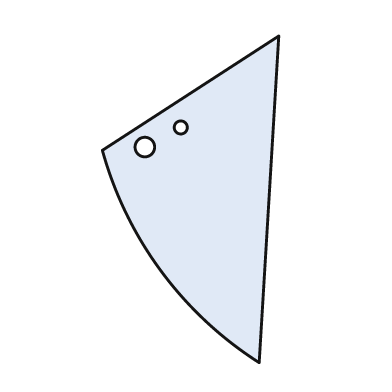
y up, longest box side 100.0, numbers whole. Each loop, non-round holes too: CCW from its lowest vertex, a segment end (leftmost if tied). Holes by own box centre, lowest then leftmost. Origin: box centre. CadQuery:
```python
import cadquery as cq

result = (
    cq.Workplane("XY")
    .moveTo(21.0, -50.0)
    .lineTo(27.0, 50.0)
    .lineTo(-27.0, 15.0)
    .threePointArc((-9.0, -22.0), (21.0, -50.0))
    .close()
    .moveTo(-14.0, 16.0)
    .circle(3.0)
    .moveTo(-3.0, 22.0)
    .circle(2.0)
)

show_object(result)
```